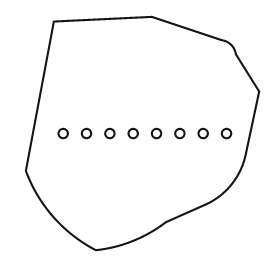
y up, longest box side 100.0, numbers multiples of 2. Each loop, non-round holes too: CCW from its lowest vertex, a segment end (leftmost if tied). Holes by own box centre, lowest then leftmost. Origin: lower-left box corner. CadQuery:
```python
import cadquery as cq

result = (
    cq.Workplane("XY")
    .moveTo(30.0, 0.0)
    .threePointArc((46.0, 4.0), (60.0, 12.0))
    .lineTo(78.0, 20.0)
    .threePointArc((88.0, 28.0), (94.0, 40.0))
    .lineTo(100.0, 68.0)
    .lineTo(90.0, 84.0)
    .threePointArc((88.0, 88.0), (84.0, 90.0))
    .lineTo(54.0, 100.0)
    .lineTo(12.0, 98.0)
    .lineTo(0.0, 34.0)
    .threePointArc((12.0, 14.0), (30.0, 0.0))
    .close()
    .moveTo(16.0, 50.0)
    .circle(2.0)
    .moveTo(26.0, 50.0)
    .circle(2.0)
    .moveTo(36.0, 50.0)
    .circle(2.0)
    .moveTo(46.0, 50.0)
    .circle(2.0)
    .moveTo(56.0, 50.0)
    .circle(2.0)
    .moveTo(66.0, 50.0)
    .circle(2.0)
    .moveTo(76.0, 50.0)
    .circle(2.0)
    .moveTo(86.0, 50.0)
    .circle(2.0)
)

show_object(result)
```